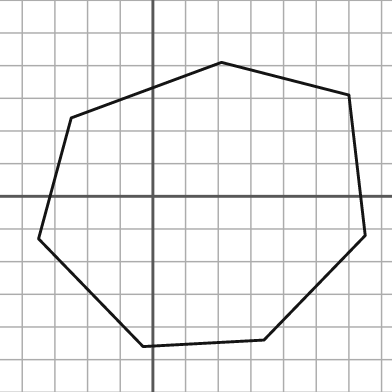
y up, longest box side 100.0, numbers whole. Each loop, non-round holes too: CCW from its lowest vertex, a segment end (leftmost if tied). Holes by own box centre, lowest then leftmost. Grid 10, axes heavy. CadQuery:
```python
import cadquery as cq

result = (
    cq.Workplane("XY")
    .moveTo(-3.0, -46.0)
    .lineTo(34.0, -44.0)
    .lineTo(65.0, -12.0)
    .lineTo(60.0, 31.0)
    .lineTo(21.0, 41.0)
    .lineTo(-25.0, 24.0)
    .lineTo(-35.0, -13.0)
    .close()
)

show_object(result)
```